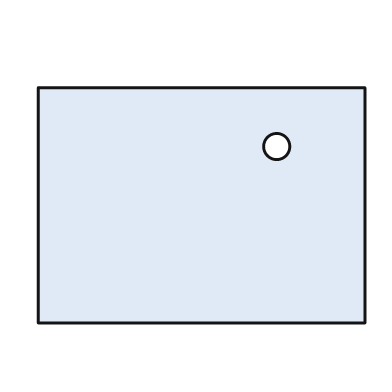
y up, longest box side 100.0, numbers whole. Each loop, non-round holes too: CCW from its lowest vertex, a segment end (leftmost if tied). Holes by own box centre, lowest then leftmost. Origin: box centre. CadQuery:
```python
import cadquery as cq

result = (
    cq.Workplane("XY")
    .moveTo(-50.0, -36.0)
    .lineTo(50.0, -36.0)
    .lineTo(50.0, 36.0)
    .lineTo(-50.0, 36.0)
    .close()
    .moveTo(23.0, 18.0)
    .circle(4.0)
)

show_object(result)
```